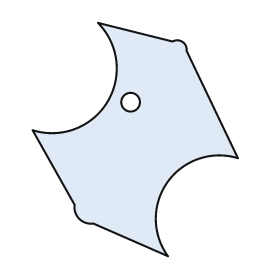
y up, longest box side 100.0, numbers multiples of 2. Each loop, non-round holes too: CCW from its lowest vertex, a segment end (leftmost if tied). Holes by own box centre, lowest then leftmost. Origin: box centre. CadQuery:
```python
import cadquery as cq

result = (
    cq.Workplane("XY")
    .moveTo(14.0, -50.0)
    .threePointArc((14.0, -18.0), (44.0, -8.0))
    .lineTo(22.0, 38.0)
    .threePointArc((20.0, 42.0), (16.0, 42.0))
    .lineTo(-16.0, 50.0)
    .threePointArc((-12.0, 16.0), (-44.0, 4.0))
    .lineTo(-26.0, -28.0)
    .threePointArc((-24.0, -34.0), (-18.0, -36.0))
    .close()
    .moveTo(-2.0, 16.0)
    .circle(4.0)
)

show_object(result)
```